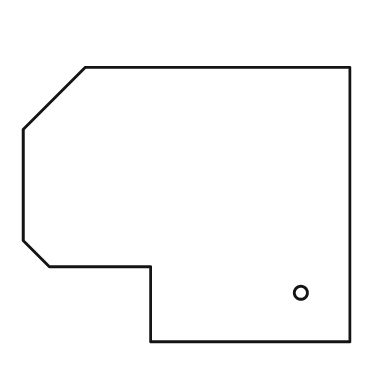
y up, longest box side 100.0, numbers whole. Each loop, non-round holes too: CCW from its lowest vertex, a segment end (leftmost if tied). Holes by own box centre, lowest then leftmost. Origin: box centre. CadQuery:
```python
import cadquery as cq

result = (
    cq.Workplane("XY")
    .moveTo(-11.0, -42.0)
    .lineTo(50.0, -42.0)
    .lineTo(50.0, 42.0)
    .lineTo(-31.0, 42.0)
    .lineTo(-50.0, 23.0)
    .lineTo(-50.0, -11.0)
    .lineTo(-42.0, -19.0)
    .lineTo(-11.0, -19.0)
    .close()
    .moveTo(35.0, -27.0)
    .circle(2.0)
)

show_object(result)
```